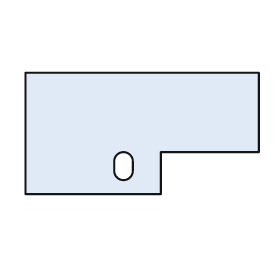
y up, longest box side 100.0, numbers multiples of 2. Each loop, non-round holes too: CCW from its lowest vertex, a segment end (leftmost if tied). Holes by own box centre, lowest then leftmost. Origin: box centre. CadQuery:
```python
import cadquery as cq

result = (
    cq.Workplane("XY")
    .moveTo(-50.0, -26.0)
    .lineTo(8.0, -26.0)
    .lineTo(8.0, -8.0)
    .lineTo(50.0, -8.0)
    .lineTo(50.0, 26.0)
    .lineTo(-50.0, 26.0)
    .close()
    .moveTo(-12.0, -16.0)
    .threePointArc((-8.0, -20.0), (-4.0, -16.0))
    .lineTo(-4.0, -12.0)
    .threePointArc((-8.0, -8.0), (-12.0, -12.0))
    .close()
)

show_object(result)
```